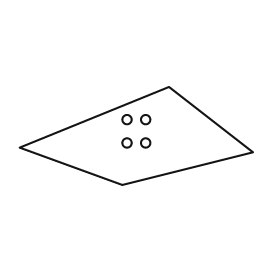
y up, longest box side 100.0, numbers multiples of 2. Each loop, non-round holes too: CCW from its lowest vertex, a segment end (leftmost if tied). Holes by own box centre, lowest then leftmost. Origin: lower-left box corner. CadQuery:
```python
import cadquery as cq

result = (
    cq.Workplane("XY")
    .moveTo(44.0, 0.0)
    .lineTo(100.0, 14.0)
    .lineTo(64.0, 42.0)
    .lineTo(0.0, 16.0)
    .close()
    .moveTo(46.0, 18.0)
    .circle(2.0)
    .moveTo(54.0, 18.0)
    .circle(2.0)
    .moveTo(46.0, 28.0)
    .circle(2.0)
    .moveTo(54.0, 28.0)
    .circle(2.0)
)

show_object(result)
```